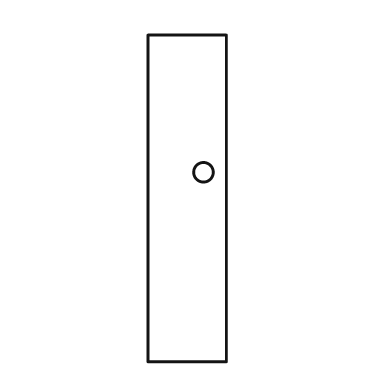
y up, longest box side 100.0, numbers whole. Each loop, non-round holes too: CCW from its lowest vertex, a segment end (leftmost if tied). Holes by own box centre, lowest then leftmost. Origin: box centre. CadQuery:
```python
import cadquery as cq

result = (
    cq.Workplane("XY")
    .moveTo(-12.0, -50.0)
    .lineTo(12.0, -50.0)
    .lineTo(12.0, 50.0)
    .lineTo(-12.0, 50.0)
    .close()
    .moveTo(5.0, 8.0)
    .circle(3.0)
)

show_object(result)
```